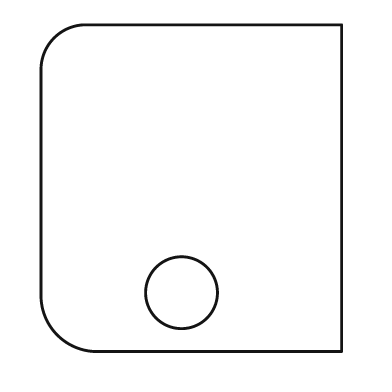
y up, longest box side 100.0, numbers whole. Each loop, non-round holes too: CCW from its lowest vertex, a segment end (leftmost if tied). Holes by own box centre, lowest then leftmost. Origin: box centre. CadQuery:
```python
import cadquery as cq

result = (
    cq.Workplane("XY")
    .moveTo(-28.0, -50.0)
    .lineTo(46.0, -50.0)
    .lineTo(46.0, 50.0)
    .lineTo(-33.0, 50.0)
    .threePointArc((-42.0, 46.0), (-46.0, 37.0))
    .lineTo(-46.0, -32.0)
    .threePointArc((-41.0, -45.0), (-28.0, -50.0))
    .close()
    .moveTo(-3.0, -32.0)
    .circle(11.0)
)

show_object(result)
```